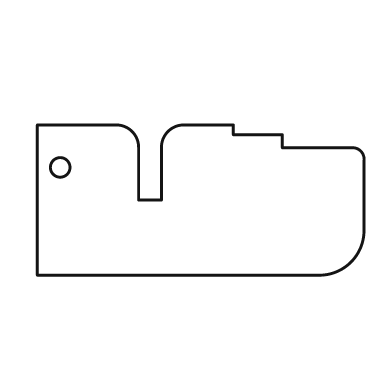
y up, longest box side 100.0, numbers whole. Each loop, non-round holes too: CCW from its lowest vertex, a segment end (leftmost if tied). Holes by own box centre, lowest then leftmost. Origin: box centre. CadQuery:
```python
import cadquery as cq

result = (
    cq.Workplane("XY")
    .moveTo(-50.0, -23.0)
    .lineTo(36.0, -23.0)
    .threePointArc((46.0, -19.0), (50.0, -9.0))
    .lineTo(50.0, 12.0)
    .threePointArc((49.0, 15.0), (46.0, 16.0))
    .lineTo(25.0, 16.0)
    .lineTo(25.0, 20.0)
    .lineTo(10.0, 20.0)
    .lineTo(10.0, 23.0)
    .lineTo(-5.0, 23.0)
    .threePointArc((-10.0, 21.0), (-12.0, 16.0))
    .lineTo(-12.0, 0.0)
    .lineTo(-19.0, 0.0)
    .lineTo(-19.0, 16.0)
    .threePointArc((-21.0, 21.0), (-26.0, 23.0))
    .lineTo(-50.0, 23.0)
    .close()
    .moveTo(-43.0, 10.0)
    .circle(3.0)
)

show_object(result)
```